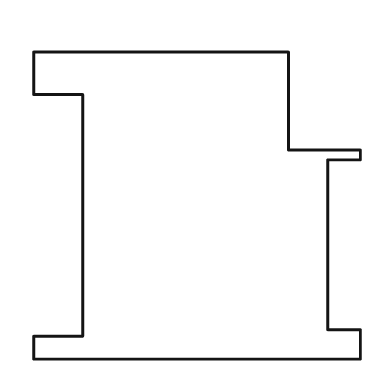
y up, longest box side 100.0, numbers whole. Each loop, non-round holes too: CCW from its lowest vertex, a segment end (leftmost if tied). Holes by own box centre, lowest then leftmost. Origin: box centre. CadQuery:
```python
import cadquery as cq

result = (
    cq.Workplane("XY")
    .moveTo(-50.0, -47.0)
    .lineTo(50.0, -47.0)
    .lineTo(50.0, -38.0)
    .lineTo(40.0, -38.0)
    .lineTo(40.0, 14.0)
    .lineTo(50.0, 14.0)
    .lineTo(50.0, 17.0)
    .lineTo(28.0, 17.0)
    .lineTo(28.0, 47.0)
    .lineTo(-50.0, 47.0)
    .lineTo(-50.0, 34.0)
    .lineTo(-35.0, 34.0)
    .lineTo(-35.0, -40.0)
    .lineTo(-50.0, -40.0)
    .close()
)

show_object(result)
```